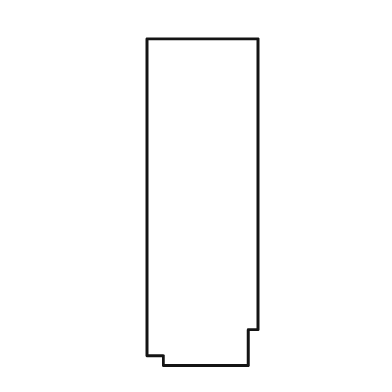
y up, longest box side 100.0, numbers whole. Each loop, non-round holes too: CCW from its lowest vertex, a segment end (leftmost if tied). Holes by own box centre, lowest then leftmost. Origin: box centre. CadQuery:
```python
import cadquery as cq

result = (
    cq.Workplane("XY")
    .moveTo(-12.0, -50.0)
    .lineTo(14.0, -50.0)
    .lineTo(14.0, -39.0)
    .lineTo(17.0, -39.0)
    .lineTo(17.0, 50.0)
    .lineTo(-17.0, 50.0)
    .lineTo(-17.0, -47.0)
    .lineTo(-12.0, -47.0)
    .close()
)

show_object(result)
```